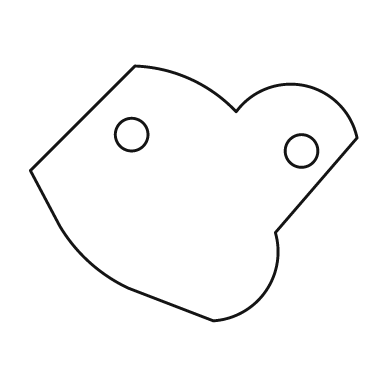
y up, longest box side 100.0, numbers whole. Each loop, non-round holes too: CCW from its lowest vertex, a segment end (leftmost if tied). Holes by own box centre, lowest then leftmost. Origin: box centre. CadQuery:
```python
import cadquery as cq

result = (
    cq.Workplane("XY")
    .moveTo(6.0, -39.0)
    .threePointArc((22.0, -30.0), (25.0, -12.0))
    .lineTo(50.0, 17.0)
    .threePointArc((34.0, 33.0), (13.0, 25.0))
    .threePointArc((-1.0, 35.0), (-18.0, 39.0))
    .lineTo(-50.0, 7.0)
    .lineTo(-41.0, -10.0)
    .threePointArc((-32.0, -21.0), (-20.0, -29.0))
    .close()
    .moveTo(33.0, 13.0)
    .circle(5.0)
    .moveTo(-19.0, 18.0)
    .circle(5.0)
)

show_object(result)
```